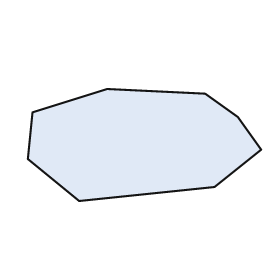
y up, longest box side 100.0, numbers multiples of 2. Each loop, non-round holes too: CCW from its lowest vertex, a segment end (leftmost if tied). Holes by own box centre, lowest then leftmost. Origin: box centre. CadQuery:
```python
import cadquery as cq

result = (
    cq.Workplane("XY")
    .moveTo(-28.0, -24.0)
    .lineTo(30.0, -18.0)
    .lineTo(50.0, -2.0)
    .lineTo(40.0, 12.0)
    .lineTo(26.0, 22.0)
    .lineTo(-16.0, 24.0)
    .lineTo(-48.0, 14.0)
    .lineTo(-50.0, -6.0)
    .close()
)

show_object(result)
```